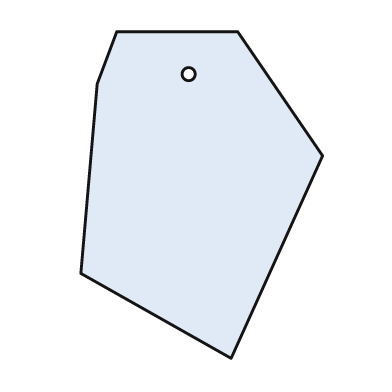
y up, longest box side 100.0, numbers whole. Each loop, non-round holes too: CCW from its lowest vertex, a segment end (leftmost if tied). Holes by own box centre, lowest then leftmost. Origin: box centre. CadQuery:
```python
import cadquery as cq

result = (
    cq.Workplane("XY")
    .moveTo(9.0, -50.0)
    .lineTo(37.0, 12.0)
    .lineTo(11.0, 50.0)
    .lineTo(-26.0, 50.0)
    .lineTo(-32.0, 34.0)
    .lineTo(-37.0, -24.0)
    .close()
    .moveTo(-4.0, 37.0)
    .circle(2.0)
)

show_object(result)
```